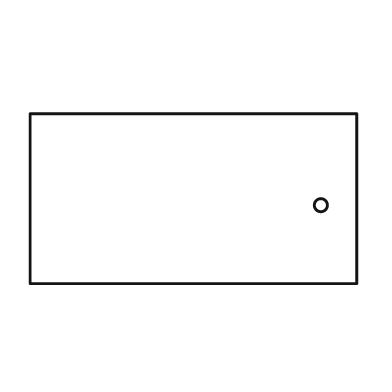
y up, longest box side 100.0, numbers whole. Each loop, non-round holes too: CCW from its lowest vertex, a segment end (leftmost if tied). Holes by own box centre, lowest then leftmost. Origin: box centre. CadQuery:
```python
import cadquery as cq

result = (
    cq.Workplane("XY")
    .moveTo(-50.0, -26.0)
    .lineTo(50.0, -26.0)
    .lineTo(50.0, 26.0)
    .lineTo(-50.0, 26.0)
    .close()
    .moveTo(39.0, -2.0)
    .circle(2.0)
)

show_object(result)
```